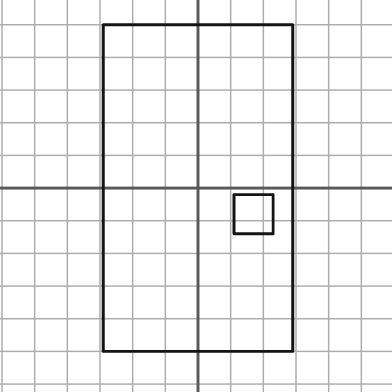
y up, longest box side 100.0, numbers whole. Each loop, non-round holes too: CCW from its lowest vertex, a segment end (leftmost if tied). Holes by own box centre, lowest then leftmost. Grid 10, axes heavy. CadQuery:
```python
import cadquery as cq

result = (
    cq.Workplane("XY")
    .moveTo(-29.0, -50.0)
    .lineTo(29.0, -50.0)
    .lineTo(29.0, 50.0)
    .lineTo(-29.0, 50.0)
    .close()
    .moveTo(11.0, -14.0)
    .lineTo(23.0, -14.0)
    .lineTo(23.0, -2.0)
    .lineTo(11.0, -2.0)
    .close()
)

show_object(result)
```